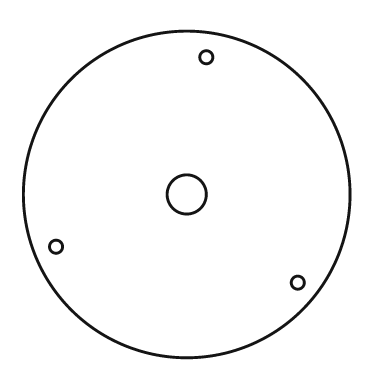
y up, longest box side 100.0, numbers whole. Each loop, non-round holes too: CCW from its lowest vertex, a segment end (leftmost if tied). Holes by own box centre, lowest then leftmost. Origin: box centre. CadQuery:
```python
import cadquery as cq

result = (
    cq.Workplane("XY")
    .moveTo(0.0, 0.0)
    .circle(50.0)
    .moveTo(34.0, -27.0)
    .circle(2.0)
    .moveTo(-40.0, -16.0)
    .circle(2.0)
    .moveTo(0.0, 0.0)
    .circle(6.0)
    .moveTo(6.0, 42.0)
    .circle(2.0)
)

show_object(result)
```